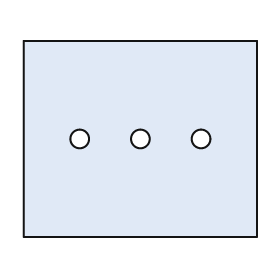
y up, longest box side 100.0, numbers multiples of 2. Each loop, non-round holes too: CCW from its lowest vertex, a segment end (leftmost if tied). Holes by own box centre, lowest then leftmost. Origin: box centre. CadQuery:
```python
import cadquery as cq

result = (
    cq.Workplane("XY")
    .moveTo(-50.0, -42.0)
    .lineTo(50.0, -42.0)
    .lineTo(50.0, 42.0)
    .lineTo(-50.0, 42.0)
    .close()
    .moveTo(-26.0, 0.0)
    .circle(4.0)
    .moveTo(0.0, 0.0)
    .circle(4.0)
    .moveTo(26.0, 0.0)
    .circle(4.0)
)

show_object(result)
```